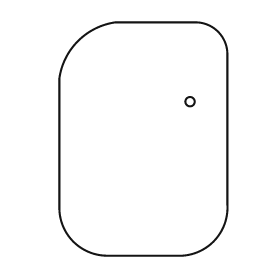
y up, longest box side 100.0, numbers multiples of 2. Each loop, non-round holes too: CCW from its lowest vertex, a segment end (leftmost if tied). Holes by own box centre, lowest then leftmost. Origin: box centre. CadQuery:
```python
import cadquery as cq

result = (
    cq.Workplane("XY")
    .moveTo(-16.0, -50.0)
    .lineTo(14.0, -50.0)
    .threePointArc((30.0, -44.0), (36.0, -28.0))
    .lineTo(36.0, 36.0)
    .threePointArc((32.0, 46.0), (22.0, 50.0))
    .lineTo(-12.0, 50.0)
    .threePointArc((-28.0, 42.0), (-36.0, 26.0))
    .lineTo(-36.0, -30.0)
    .threePointArc((-30.0, -44.0), (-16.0, -50.0))
    .close()
    .moveTo(20.0, 16.0)
    .circle(2.0)
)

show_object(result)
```